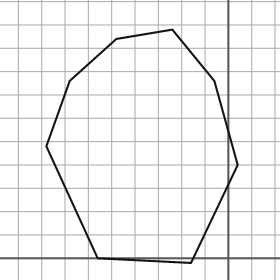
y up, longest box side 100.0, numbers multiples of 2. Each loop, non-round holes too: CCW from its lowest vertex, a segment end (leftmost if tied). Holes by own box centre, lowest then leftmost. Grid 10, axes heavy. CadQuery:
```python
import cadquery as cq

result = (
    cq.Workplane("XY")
    .moveTo(-16.0, -2.0)
    .lineTo(4.0, 40.0)
    .lineTo(-6.0, 76.0)
    .lineTo(-24.0, 98.0)
    .lineTo(-48.0, 94.0)
    .lineTo(-68.0, 76.0)
    .lineTo(-78.0, 48.0)
    .lineTo(-56.0, 0.0)
    .close()
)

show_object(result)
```